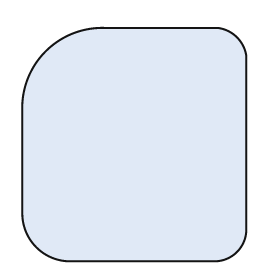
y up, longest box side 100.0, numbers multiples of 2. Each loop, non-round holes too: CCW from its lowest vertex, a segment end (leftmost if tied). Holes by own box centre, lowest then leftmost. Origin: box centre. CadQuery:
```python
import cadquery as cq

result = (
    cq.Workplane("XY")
    .moveTo(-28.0, -50.0)
    .lineTo(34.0, -50.0)
    .threePointArc((44.0, -46.0), (48.0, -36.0))
    .lineTo(48.0, 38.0)
    .threePointArc((44.0, 46.0), (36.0, 50.0))
    .lineTo(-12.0, 50.0)
    .threePointArc((-38.0, 40.0), (-48.0, 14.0))
    .lineTo(-48.0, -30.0)
    .threePointArc((-42.0, -44.0), (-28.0, -50.0))
    .close()
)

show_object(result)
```